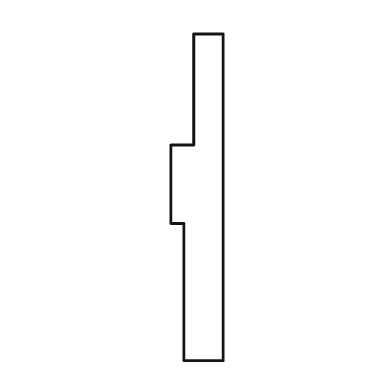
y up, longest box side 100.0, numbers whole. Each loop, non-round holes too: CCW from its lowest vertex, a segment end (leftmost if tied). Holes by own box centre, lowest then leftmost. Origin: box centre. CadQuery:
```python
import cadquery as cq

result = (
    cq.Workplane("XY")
    .moveTo(-4.0, -50.0)
    .lineTo(8.0, -50.0)
    .lineTo(8.0, 50.0)
    .lineTo(-1.0, 50.0)
    .lineTo(-1.0, 16.0)
    .lineTo(-8.0, 16.0)
    .lineTo(-8.0, -8.0)
    .lineTo(-4.0, -8.0)
    .close()
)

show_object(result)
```